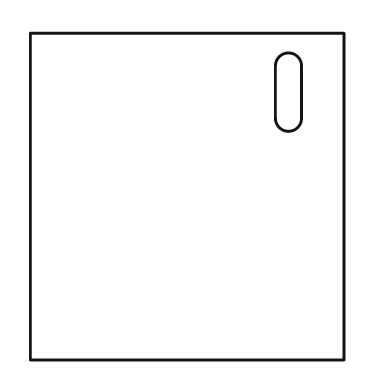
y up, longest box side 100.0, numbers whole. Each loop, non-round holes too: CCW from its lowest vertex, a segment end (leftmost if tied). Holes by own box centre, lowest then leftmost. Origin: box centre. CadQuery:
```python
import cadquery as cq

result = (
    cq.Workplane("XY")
    .moveTo(-48.0, -50.0)
    .lineTo(48.0, -50.0)
    .lineTo(48.0, 50.0)
    .lineTo(-48.0, 50.0)
    .close()
    .moveTo(27.0, 24.0)
    .threePointArc((31.0, 20.0), (35.0, 24.0))
    .lineTo(35.0, 40.0)
    .threePointArc((31.0, 44.0), (27.0, 40.0))
    .close()
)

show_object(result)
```